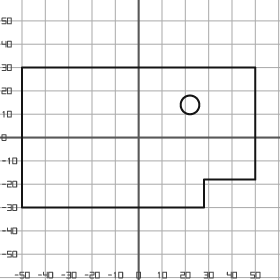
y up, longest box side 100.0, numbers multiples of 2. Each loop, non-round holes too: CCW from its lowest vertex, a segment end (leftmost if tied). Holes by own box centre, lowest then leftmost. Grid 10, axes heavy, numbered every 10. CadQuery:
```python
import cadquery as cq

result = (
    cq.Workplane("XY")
    .moveTo(-50.0, -30.0)
    .lineTo(28.0, -30.0)
    .lineTo(28.0, -18.0)
    .lineTo(50.0, -18.0)
    .lineTo(50.0, 30.0)
    .lineTo(-50.0, 30.0)
    .close()
    .moveTo(22.0, 14.0)
    .circle(4.0)
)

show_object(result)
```